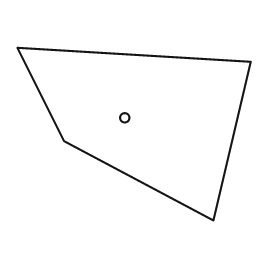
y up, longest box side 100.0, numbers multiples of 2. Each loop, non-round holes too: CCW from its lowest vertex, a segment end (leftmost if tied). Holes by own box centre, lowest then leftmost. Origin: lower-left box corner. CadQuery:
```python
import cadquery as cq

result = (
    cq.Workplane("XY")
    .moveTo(84.0, 0.0)
    .lineTo(100.0, 68.0)
    .lineTo(0.0, 74.0)
    .lineTo(20.0, 34.0)
    .close()
    .moveTo(46.0, 44.0)
    .circle(2.0)
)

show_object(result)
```